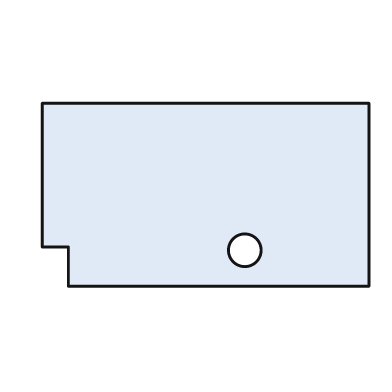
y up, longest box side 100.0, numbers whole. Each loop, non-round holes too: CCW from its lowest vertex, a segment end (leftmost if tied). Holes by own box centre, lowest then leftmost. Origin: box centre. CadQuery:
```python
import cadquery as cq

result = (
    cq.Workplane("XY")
    .moveTo(-42.0, -28.0)
    .lineTo(50.0, -28.0)
    .lineTo(50.0, 28.0)
    .lineTo(-50.0, 28.0)
    .lineTo(-50.0, -16.0)
    .lineTo(-42.0, -16.0)
    .close()
    .moveTo(12.0, -17.0)
    .circle(5.0)
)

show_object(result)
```